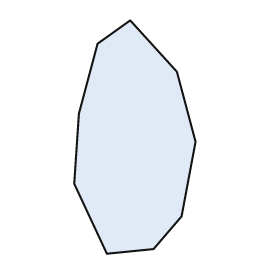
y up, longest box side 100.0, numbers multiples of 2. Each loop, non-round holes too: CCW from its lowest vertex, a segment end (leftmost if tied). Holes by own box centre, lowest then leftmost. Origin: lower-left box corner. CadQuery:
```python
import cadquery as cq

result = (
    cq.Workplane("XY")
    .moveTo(14.0, 0.0)
    .lineTo(34.0, 2.0)
    .lineTo(46.0, 16.0)
    .lineTo(52.0, 48.0)
    .lineTo(44.0, 78.0)
    .lineTo(24.0, 100.0)
    .lineTo(10.0, 90.0)
    .lineTo(2.0, 60.0)
    .lineTo(0.0, 30.0)
    .close()
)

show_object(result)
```